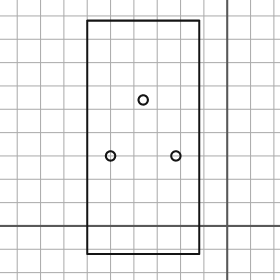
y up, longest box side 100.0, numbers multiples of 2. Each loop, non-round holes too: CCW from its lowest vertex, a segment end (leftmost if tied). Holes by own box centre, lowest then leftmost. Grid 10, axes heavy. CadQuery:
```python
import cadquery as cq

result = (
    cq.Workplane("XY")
    .moveTo(-60.0, -12.0)
    .lineTo(-12.0, -12.0)
    .lineTo(-12.0, 88.0)
    .lineTo(-60.0, 88.0)
    .close()
    .moveTo(-50.0, 30.0)
    .circle(2.0)
    .moveTo(-22.0, 30.0)
    .circle(2.0)
    .moveTo(-36.0, 54.0)
    .circle(2.0)
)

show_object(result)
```